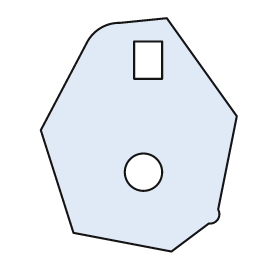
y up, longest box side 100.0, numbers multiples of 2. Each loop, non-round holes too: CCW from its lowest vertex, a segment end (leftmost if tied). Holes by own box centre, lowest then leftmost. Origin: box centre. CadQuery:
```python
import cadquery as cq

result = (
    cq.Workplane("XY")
    .moveTo(14.0, -50.0)
    .lineTo(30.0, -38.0)
    .threePointArc((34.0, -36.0), (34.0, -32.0))
    .lineTo(42.0, 8.0)
    .lineTo(12.0, 50.0)
    .lineTo(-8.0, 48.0)
    .threePointArc((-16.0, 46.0), (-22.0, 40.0))
    .lineTo(-42.0, 2.0)
    .lineTo(-28.0, -42.0)
    .close()
    .moveTo(2.0, -16.0)
    .circle(8.0)
    .moveTo(-2.0, 24.0)
    .lineTo(10.0, 24.0)
    .lineTo(10.0, 40.0)
    .lineTo(-2.0, 40.0)
    .close()
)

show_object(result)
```